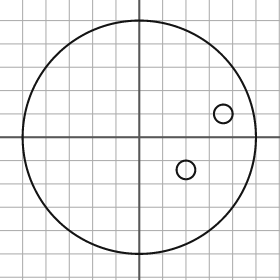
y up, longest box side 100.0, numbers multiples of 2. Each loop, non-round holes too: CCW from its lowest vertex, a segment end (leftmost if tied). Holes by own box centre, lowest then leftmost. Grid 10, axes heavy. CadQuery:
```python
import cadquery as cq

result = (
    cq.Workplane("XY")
    .moveTo(0.0, 0.0)
    .circle(50.0)
    .moveTo(20.0, -14.0)
    .circle(4.0)
    .moveTo(36.0, 10.0)
    .circle(4.0)
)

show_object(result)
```